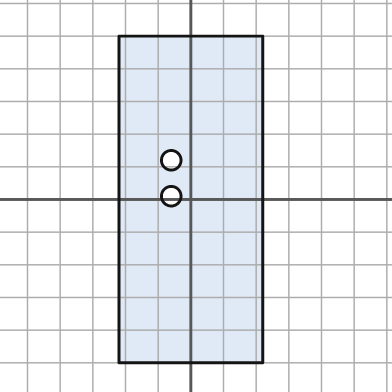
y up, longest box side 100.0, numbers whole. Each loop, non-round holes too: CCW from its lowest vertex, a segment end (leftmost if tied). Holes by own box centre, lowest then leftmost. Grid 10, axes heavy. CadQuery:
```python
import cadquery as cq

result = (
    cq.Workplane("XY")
    .moveTo(-22.0, -50.0)
    .lineTo(22.0, -50.0)
    .lineTo(22.0, 50.0)
    .lineTo(-22.0, 50.0)
    .close()
    .moveTo(-6.0, 1.0)
    .circle(3.0)
    .moveTo(-6.0, 12.0)
    .circle(3.0)
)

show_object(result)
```